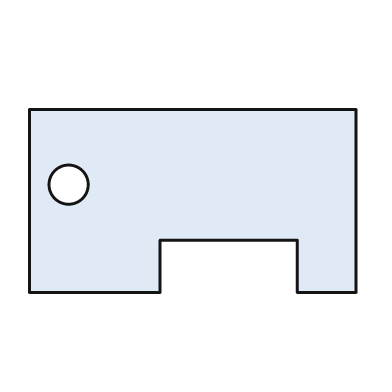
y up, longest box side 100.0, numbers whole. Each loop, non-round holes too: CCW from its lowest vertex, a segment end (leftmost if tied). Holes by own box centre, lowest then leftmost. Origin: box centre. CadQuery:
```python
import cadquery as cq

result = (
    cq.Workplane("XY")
    .moveTo(-50.0, -28.0)
    .lineTo(-10.0, -28.0)
    .lineTo(-10.0, -12.0)
    .lineTo(32.0, -12.0)
    .lineTo(32.0, -28.0)
    .lineTo(50.0, -28.0)
    .lineTo(50.0, 28.0)
    .lineTo(-50.0, 28.0)
    .close()
    .moveTo(-38.0, 5.0)
    .circle(6.0)
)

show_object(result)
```